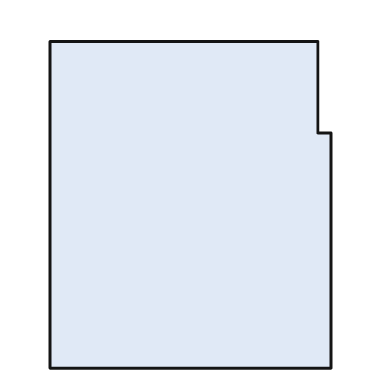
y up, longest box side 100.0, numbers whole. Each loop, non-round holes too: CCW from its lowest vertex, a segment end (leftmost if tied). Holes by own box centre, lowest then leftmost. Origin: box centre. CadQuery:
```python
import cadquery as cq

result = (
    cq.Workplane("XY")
    .moveTo(-43.0, -50.0)
    .lineTo(43.0, -50.0)
    .lineTo(43.0, 22.0)
    .lineTo(39.0, 22.0)
    .lineTo(39.0, 50.0)
    .lineTo(-43.0, 50.0)
    .close()
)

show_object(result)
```